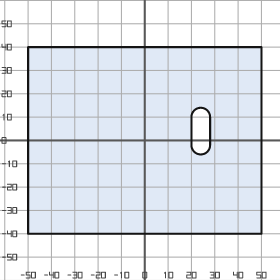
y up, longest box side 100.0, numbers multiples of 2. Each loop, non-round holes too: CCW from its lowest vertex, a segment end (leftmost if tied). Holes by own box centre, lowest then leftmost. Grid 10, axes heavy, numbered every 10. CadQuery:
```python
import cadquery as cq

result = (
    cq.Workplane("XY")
    .moveTo(-50.0, -40.0)
    .lineTo(50.0, -40.0)
    .lineTo(50.0, 40.0)
    .lineTo(-50.0, 40.0)
    .close()
    .moveTo(20.0, -2.0)
    .threePointArc((24.0, -6.0), (28.0, -2.0))
    .lineTo(28.0, 10.0)
    .threePointArc((24.0, 14.0), (20.0, 10.0))
    .close()
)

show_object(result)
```